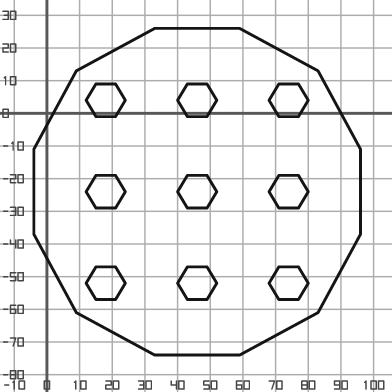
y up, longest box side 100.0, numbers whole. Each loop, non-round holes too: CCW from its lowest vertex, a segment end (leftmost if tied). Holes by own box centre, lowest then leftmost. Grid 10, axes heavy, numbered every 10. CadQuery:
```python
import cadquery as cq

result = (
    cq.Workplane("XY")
    .moveTo(33.0, -74.0)
    .lineTo(59.0, -74.0)
    .lineTo(83.0, -61.0)
    .lineTo(96.0, -37.0)
    .lineTo(96.0, -11.0)
    .lineTo(83.0, 13.0)
    .lineTo(59.0, 26.0)
    .lineTo(33.0, 26.0)
    .lineTo(9.0, 13.0)
    .lineTo(-4.0, -11.0)
    .lineTo(-4.0, -37.0)
    .lineTo(9.0, -61.0)
    .close()
    .moveTo(15.0, -57.0)
    .lineTo(21.0, -57.0)
    .lineTo(24.0, -52.0)
    .lineTo(21.0, -47.0)
    .lineTo(15.0, -47.0)
    .lineTo(12.0, -52.0)
    .close()
    .moveTo(43.0, -57.0)
    .lineTo(49.0, -57.0)
    .lineTo(52.0, -52.0)
    .lineTo(49.0, -47.0)
    .lineTo(43.0, -47.0)
    .lineTo(40.0, -52.0)
    .close()
    .moveTo(71.0, -57.0)
    .lineTo(77.0, -57.0)
    .lineTo(80.0, -52.0)
    .lineTo(77.0, -47.0)
    .lineTo(71.0, -47.0)
    .lineTo(68.0, -52.0)
    .close()
    .moveTo(15.0, -29.0)
    .lineTo(21.0, -29.0)
    .lineTo(24.0, -24.0)
    .lineTo(21.0, -19.0)
    .lineTo(15.0, -19.0)
    .lineTo(12.0, -24.0)
    .close()
    .moveTo(43.0, -29.0)
    .lineTo(49.0, -29.0)
    .lineTo(52.0, -24.0)
    .lineTo(49.0, -19.0)
    .lineTo(43.0, -19.0)
    .lineTo(40.0, -24.0)
    .close()
    .moveTo(71.0, -29.0)
    .lineTo(77.0, -29.0)
    .lineTo(80.0, -24.0)
    .lineTo(77.0, -19.0)
    .lineTo(71.0, -19.0)
    .lineTo(68.0, -24.0)
    .close()
    .moveTo(15.0, -1.0)
    .lineTo(21.0, -1.0)
    .lineTo(24.0, 4.0)
    .lineTo(21.0, 9.0)
    .lineTo(15.0, 9.0)
    .lineTo(12.0, 4.0)
    .close()
    .moveTo(43.0, -1.0)
    .lineTo(49.0, -1.0)
    .lineTo(52.0, 4.0)
    .lineTo(49.0, 9.0)
    .lineTo(43.0, 9.0)
    .lineTo(40.0, 4.0)
    .close()
    .moveTo(71.0, -1.0)
    .lineTo(77.0, -1.0)
    .lineTo(80.0, 4.0)
    .lineTo(77.0, 9.0)
    .lineTo(71.0, 9.0)
    .lineTo(68.0, 4.0)
    .close()
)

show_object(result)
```